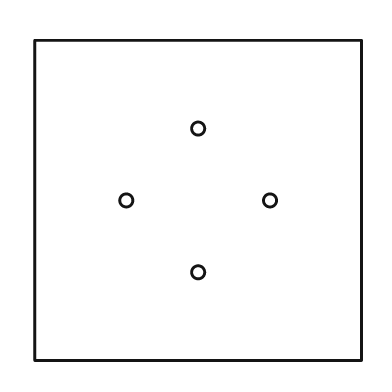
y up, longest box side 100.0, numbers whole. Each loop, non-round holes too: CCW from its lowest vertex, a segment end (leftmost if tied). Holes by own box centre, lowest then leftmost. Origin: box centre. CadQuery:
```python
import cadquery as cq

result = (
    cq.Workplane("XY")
    .moveTo(-50.0, -49.0)
    .lineTo(50.0, -49.0)
    .lineTo(50.0, 49.0)
    .lineTo(-50.0, 49.0)
    .close()
    .moveTo(0.0, -22.0)
    .circle(2.0)
    .moveTo(-22.0, 0.0)
    .circle(2.0)
    .moveTo(22.0, 0.0)
    .circle(2.0)
    .moveTo(0.0, 22.0)
    .circle(2.0)
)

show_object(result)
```